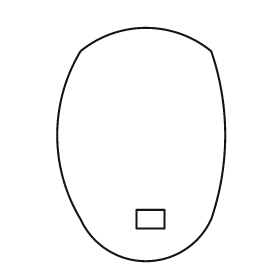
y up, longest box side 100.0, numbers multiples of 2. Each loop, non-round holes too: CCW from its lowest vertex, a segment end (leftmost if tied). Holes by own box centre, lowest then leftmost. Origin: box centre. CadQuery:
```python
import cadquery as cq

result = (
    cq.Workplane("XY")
    .moveTo(-26.0, -32.0)
    .threePointArc((2.0, -50.0), (30.0, -32.0))
    .threePointArc((36.0, 4.0), (30.0, 40.0))
    .threePointArc((2.0, 50.0), (-26.0, 40.0))
    .threePointArc((-36.0, 4.0), (-26.0, -32.0))
    .close()
    .moveTo(-2.0, -36.0)
    .lineTo(10.0, -36.0)
    .lineTo(10.0, -28.0)
    .lineTo(-2.0, -28.0)
    .close()
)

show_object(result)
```